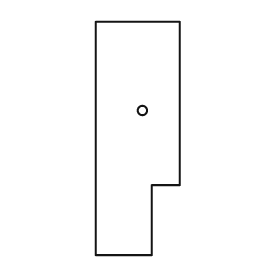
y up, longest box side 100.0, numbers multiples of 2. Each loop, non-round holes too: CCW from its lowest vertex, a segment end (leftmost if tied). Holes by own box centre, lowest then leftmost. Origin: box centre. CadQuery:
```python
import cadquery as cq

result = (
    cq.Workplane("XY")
    .moveTo(-18.0, -50.0)
    .lineTo(6.0, -50.0)
    .lineTo(6.0, -20.0)
    .lineTo(18.0, -20.0)
    .lineTo(18.0, 50.0)
    .lineTo(-18.0, 50.0)
    .close()
    .moveTo(2.0, 12.0)
    .circle(2.0)
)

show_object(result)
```